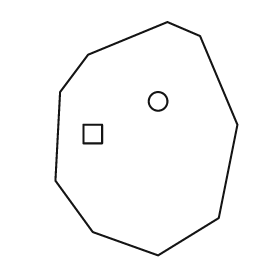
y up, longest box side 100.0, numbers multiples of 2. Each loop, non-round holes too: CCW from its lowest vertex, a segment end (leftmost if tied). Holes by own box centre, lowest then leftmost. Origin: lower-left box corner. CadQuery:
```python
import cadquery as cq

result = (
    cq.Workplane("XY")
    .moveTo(44.0, 0.0)
    .lineTo(70.0, 16.0)
    .lineTo(78.0, 56.0)
    .lineTo(62.0, 94.0)
    .lineTo(48.0, 100.0)
    .lineTo(14.0, 86.0)
    .lineTo(2.0, 70.0)
    .lineTo(0.0, 32.0)
    .lineTo(16.0, 10.0)
    .close()
    .moveTo(12.0, 48.0)
    .lineTo(20.0, 48.0)
    .lineTo(20.0, 56.0)
    .lineTo(12.0, 56.0)
    .close()
    .moveTo(44.0, 66.0)
    .circle(4.0)
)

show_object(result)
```